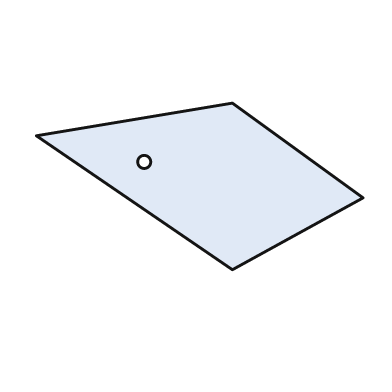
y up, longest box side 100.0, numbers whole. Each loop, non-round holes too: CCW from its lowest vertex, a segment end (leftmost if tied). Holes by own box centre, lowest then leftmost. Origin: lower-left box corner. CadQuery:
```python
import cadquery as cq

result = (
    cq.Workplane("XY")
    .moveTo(60.0, 0.0)
    .lineTo(100.0, 22.0)
    .lineTo(60.0, 51.0)
    .lineTo(0.0, 41.0)
    .close()
    .moveTo(33.0, 33.0)
    .circle(2.0)
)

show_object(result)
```